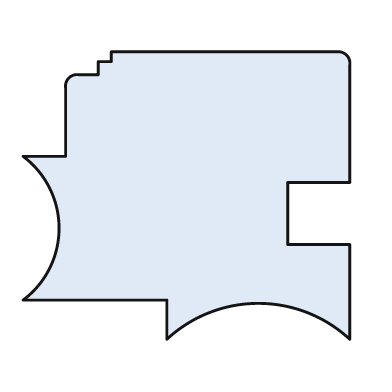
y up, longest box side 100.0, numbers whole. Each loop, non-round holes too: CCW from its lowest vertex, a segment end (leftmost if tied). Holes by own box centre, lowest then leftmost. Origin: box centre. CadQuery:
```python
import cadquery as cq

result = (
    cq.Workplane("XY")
    .moveTo(-6.0, -44.0)
    .threePointArc((22.0, -33.0), (50.0, -44.0))
    .lineTo(50.0, -15.0)
    .lineTo(31.0, -15.0)
    .lineTo(31.0, 4.0)
    .lineTo(50.0, 4.0)
    .lineTo(50.0, 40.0)
    .threePointArc((49.0, 43.0), (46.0, 44.0))
    .lineTo(-23.0, 44.0)
    .lineTo(-23.0, 41.0)
    .lineTo(-27.0, 41.0)
    .lineTo(-27.0, 37.0)
    .lineTo(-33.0, 37.0)
    .threePointArc((-36.0, 36.0), (-37.0, 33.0))
    .lineTo(-37.0, 12.0)
    .lineTo(-50.0, 12.0)
    .threePointArc((-39.0, -10.0), (-50.0, -32.0))
    .lineTo(-6.0, -32.0)
    .close()
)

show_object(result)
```